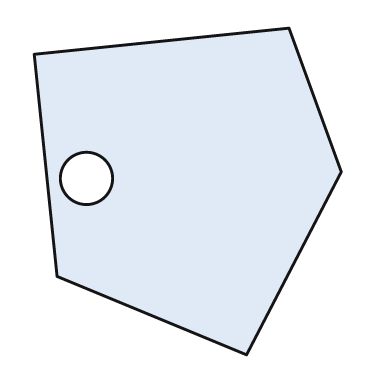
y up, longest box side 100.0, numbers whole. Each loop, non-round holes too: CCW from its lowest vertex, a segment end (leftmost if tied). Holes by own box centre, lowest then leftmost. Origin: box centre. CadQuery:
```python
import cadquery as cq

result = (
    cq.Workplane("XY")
    .moveTo(18.0, -50.0)
    .lineTo(47.0, 6.0)
    .lineTo(31.0, 50.0)
    .lineTo(-47.0, 42.0)
    .lineTo(-40.0, -26.0)
    .close()
    .moveTo(-31.0, 4.0)
    .circle(8.0)
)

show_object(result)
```